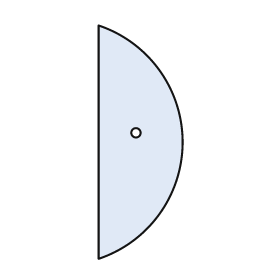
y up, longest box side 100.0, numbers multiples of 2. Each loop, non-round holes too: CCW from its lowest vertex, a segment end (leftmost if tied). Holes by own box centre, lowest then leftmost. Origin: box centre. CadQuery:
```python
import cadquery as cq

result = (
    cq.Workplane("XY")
    .moveTo(-18.0, -50.0)
    .threePointArc((18.0, 0.0), (-18.0, 50.0))
    .close()
    .moveTo(-2.0, 4.0)
    .circle(2.0)
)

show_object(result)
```